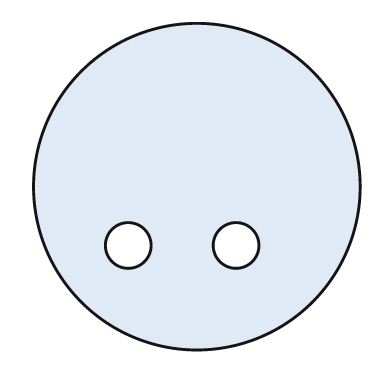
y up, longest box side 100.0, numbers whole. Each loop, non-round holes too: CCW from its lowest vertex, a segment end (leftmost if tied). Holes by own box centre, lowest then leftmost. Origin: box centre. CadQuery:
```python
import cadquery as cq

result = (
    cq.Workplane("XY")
    .moveTo(0.0, 0.0)
    .circle(50.0)
    .moveTo(-21.0, -18.0)
    .circle(7.0)
    .moveTo(12.0, -18.0)
    .circle(7.0)
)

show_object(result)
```